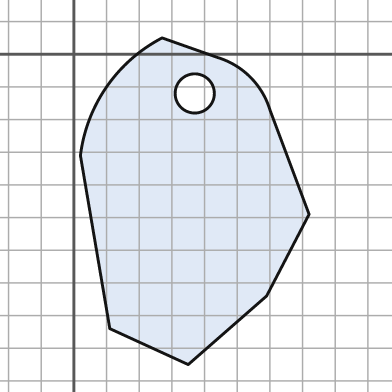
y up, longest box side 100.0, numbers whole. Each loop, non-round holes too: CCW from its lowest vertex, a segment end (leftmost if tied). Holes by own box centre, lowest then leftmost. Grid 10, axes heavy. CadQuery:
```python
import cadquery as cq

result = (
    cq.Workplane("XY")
    .moveTo(35.0, -95.0)
    .lineTo(59.0, -74.0)
    .lineTo(72.0, -49.0)
    .lineTo(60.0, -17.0)
    .threePointArc((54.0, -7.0), (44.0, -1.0))
    .lineTo(27.0, 5.0)
    .threePointArc((10.0, -10.0), (2.0, -31.0))
    .lineTo(11.0, -84.0)
    .close()
    .moveTo(37.0, -12.0)
    .circle(6.0)
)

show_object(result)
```